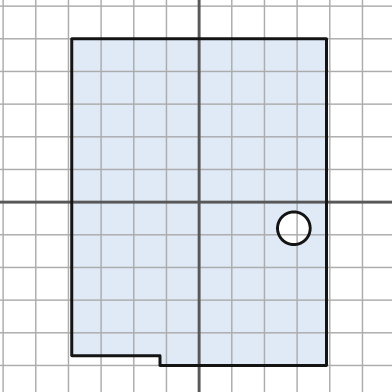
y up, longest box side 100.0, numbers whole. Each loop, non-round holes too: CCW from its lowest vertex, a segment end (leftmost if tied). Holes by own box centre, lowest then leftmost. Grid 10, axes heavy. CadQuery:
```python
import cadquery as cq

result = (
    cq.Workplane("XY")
    .moveTo(-12.0, -50.0)
    .lineTo(39.0, -50.0)
    .lineTo(39.0, 50.0)
    .lineTo(-39.0, 50.0)
    .lineTo(-39.0, -47.0)
    .lineTo(-12.0, -47.0)
    .close()
    .moveTo(29.0, -8.0)
    .circle(5.0)
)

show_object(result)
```